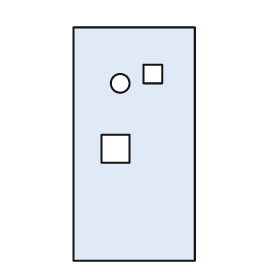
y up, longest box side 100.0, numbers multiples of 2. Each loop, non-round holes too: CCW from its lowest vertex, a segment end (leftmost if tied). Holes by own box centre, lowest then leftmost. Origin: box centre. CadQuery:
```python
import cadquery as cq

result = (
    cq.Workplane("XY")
    .moveTo(-26.0, -50.0)
    .lineTo(26.0, -50.0)
    .lineTo(26.0, 50.0)
    .lineTo(-26.0, 50.0)
    .close()
    .moveTo(-14.0, -8.0)
    .lineTo(-2.0, -8.0)
    .lineTo(-2.0, 4.0)
    .lineTo(-14.0, 4.0)
    .close()
    .moveTo(-6.0, 26.0)
    .circle(4.0)
    .moveTo(4.0, 26.0)
    .lineTo(12.0, 26.0)
    .lineTo(12.0, 34.0)
    .lineTo(4.0, 34.0)
    .close()
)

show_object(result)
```